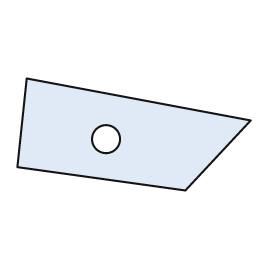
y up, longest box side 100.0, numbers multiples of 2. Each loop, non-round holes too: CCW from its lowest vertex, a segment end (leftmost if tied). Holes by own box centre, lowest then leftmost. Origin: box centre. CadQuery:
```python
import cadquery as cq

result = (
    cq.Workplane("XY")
    .moveTo(22.0, -24.0)
    .lineTo(50.0, 6.0)
    .lineTo(-46.0, 24.0)
    .lineTo(-50.0, -14.0)
    .close()
    .moveTo(-12.0, -2.0)
    .circle(6.0)
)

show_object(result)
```